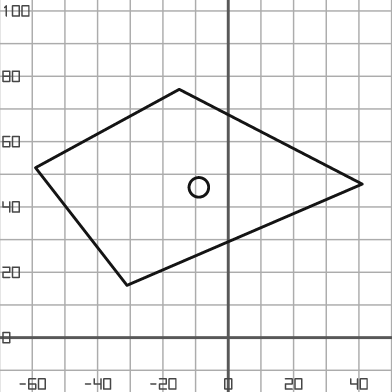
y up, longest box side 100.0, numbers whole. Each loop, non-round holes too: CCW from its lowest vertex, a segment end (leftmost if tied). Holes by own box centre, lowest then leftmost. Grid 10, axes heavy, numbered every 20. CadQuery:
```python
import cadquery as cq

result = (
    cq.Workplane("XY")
    .moveTo(-31.0, 16.0)
    .lineTo(41.0, 47.0)
    .lineTo(-15.0, 76.0)
    .lineTo(-59.0, 52.0)
    .close()
    .moveTo(-9.0, 46.0)
    .circle(3.0)
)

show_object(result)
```